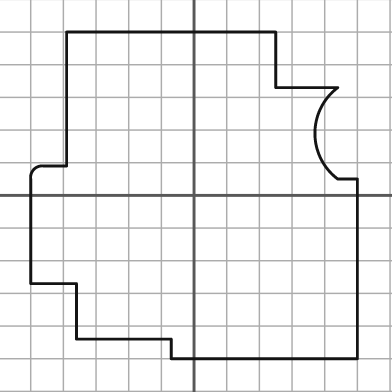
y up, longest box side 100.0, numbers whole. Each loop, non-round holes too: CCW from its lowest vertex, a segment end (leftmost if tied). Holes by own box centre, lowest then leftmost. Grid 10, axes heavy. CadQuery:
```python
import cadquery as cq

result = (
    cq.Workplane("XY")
    .moveTo(-7.0, -50.0)
    .lineTo(50.0, -50.0)
    .lineTo(50.0, 5.0)
    .lineTo(44.0, 5.0)
    .threePointArc((37.0, 19.0), (44.0, 33.0))
    .lineTo(25.0, 33.0)
    .lineTo(25.0, 50.0)
    .lineTo(-39.0, 50.0)
    .lineTo(-39.0, 9.0)
    .lineTo(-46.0, 9.0)
    .threePointArc((-49.0, 8.0), (-50.0, 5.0))
    .lineTo(-50.0, -27.0)
    .lineTo(-36.0, -27.0)
    .lineTo(-36.0, -44.0)
    .lineTo(-7.0, -44.0)
    .close()
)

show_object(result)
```